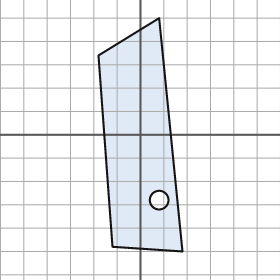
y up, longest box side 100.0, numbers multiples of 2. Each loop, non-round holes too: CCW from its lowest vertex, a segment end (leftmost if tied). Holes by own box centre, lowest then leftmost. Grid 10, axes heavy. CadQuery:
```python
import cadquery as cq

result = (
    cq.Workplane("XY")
    .moveTo(18.0, -50.0)
    .lineTo(8.0, 50.0)
    .lineTo(-18.0, 34.0)
    .lineTo(-12.0, -48.0)
    .close()
    .moveTo(8.0, -28.0)
    .circle(4.0)
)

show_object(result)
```